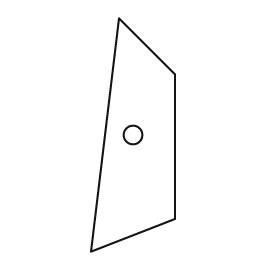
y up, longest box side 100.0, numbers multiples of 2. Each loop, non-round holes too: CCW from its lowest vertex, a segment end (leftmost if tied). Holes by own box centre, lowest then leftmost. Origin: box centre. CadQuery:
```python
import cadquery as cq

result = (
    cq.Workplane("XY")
    .moveTo(-18.0, -50.0)
    .lineTo(18.0, -36.0)
    .lineTo(18.0, 26.0)
    .lineTo(-6.0, 50.0)
    .close()
    .moveTo(0.0, 0.0)
    .circle(4.0)
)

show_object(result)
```